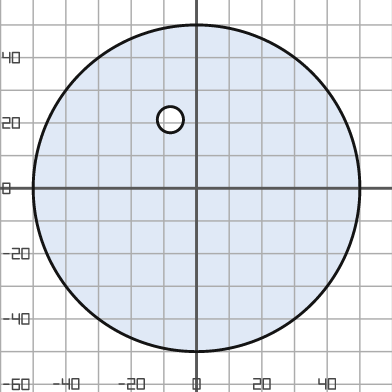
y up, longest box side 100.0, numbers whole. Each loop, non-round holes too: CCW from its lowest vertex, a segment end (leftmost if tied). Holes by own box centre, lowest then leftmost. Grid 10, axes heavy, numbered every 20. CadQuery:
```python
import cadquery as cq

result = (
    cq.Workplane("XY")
    .moveTo(0.0, 0.0)
    .circle(50.0)
    .moveTo(-8.0, 21.0)
    .circle(4.0)
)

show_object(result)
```